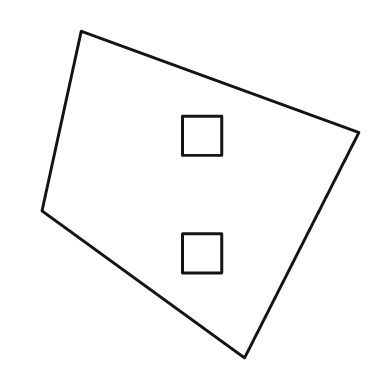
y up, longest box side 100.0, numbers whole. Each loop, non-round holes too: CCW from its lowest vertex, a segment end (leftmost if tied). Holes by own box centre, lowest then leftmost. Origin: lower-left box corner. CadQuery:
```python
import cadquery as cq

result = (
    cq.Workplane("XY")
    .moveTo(62.0, 0.0)
    .lineTo(97.0, 69.0)
    .lineTo(12.0, 100.0)
    .lineTo(0.0, 45.0)
    .close()
    .moveTo(43.0, 26.0)
    .lineTo(55.0, 26.0)
    .lineTo(55.0, 38.0)
    .lineTo(43.0, 38.0)
    .close()
    .moveTo(43.0, 62.0)
    .lineTo(55.0, 62.0)
    .lineTo(55.0, 74.0)
    .lineTo(43.0, 74.0)
    .close()
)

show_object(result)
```